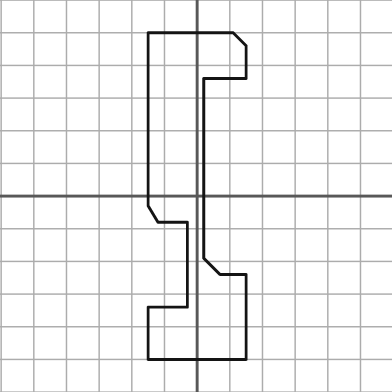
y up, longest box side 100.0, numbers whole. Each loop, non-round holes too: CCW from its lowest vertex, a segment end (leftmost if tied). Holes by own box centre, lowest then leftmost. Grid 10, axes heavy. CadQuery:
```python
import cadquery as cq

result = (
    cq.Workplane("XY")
    .moveTo(-15.0, -50.0)
    .lineTo(15.0, -50.0)
    .lineTo(15.0, -24.0)
    .lineTo(7.0, -24.0)
    .lineTo(2.0, -19.0)
    .lineTo(2.0, 36.0)
    .lineTo(15.0, 36.0)
    .lineTo(15.0, 46.0)
    .lineTo(11.0, 50.0)
    .lineTo(-15.0, 50.0)
    .lineTo(-15.0, -3.0)
    .lineTo(-12.0, -8.0)
    .lineTo(-3.0, -8.0)
    .lineTo(-3.0, -34.0)
    .lineTo(-15.0, -34.0)
    .close()
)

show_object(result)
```